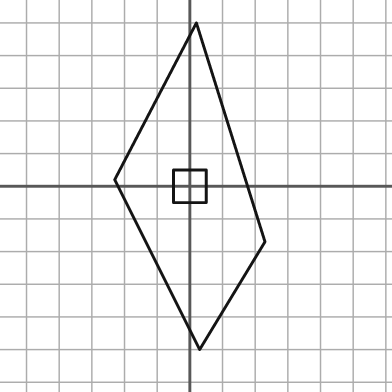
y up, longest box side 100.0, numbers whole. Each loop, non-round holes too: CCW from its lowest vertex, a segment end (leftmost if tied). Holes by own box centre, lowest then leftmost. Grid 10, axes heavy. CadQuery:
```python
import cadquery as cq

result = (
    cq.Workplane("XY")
    .moveTo(3.0, -50.0)
    .lineTo(23.0, -17.0)
    .lineTo(2.0, 50.0)
    .lineTo(-23.0, 2.0)
    .close()
    .moveTo(-5.0, -5.0)
    .lineTo(5.0, -5.0)
    .lineTo(5.0, 5.0)
    .lineTo(-5.0, 5.0)
    .close()
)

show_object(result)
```